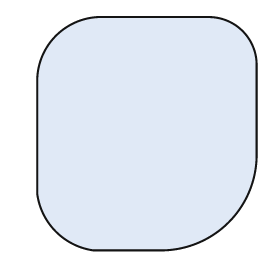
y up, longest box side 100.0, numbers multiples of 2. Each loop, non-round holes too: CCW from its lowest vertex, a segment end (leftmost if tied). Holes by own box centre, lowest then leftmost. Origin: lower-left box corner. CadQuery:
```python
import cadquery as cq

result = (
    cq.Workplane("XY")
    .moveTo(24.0, 0.0)
    .lineTo(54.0, 0.0)
    .threePointArc((82.0, 12.0), (94.0, 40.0))
    .lineTo(94.0, 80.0)
    .threePointArc((88.0, 94.0), (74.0, 100.0))
    .lineTo(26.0, 100.0)
    .threePointArc((8.0, 92.0), (0.0, 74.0))
    .lineTo(0.0, 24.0)
    .threePointArc((8.0, 8.0), (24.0, 0.0))
    .close()
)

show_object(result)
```